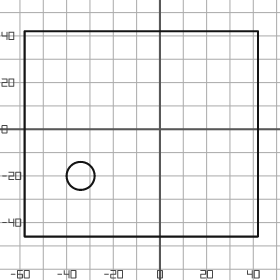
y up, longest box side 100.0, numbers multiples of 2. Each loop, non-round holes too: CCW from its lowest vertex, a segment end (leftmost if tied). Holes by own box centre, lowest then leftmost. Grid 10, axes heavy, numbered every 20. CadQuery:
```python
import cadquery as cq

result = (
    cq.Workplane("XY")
    .moveTo(-58.0, -46.0)
    .lineTo(42.0, -46.0)
    .lineTo(42.0, 42.0)
    .lineTo(-58.0, 42.0)
    .close()
    .moveTo(-34.0, -20.0)
    .circle(6.0)
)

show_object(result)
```